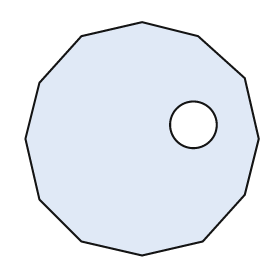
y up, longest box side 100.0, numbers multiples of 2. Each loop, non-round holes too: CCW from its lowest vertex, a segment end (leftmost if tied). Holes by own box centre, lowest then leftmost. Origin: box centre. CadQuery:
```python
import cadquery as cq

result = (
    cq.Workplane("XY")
    .moveTo(0.0, -50.0)
    .lineTo(26.0, -44.0)
    .lineTo(44.0, -24.0)
    .lineTo(50.0, 0.0)
    .lineTo(44.0, 26.0)
    .lineTo(24.0, 44.0)
    .lineTo(0.0, 50.0)
    .lineTo(-26.0, 44.0)
    .lineTo(-44.0, 24.0)
    .lineTo(-50.0, 0.0)
    .lineTo(-44.0, -26.0)
    .lineTo(-26.0, -44.0)
    .close()
    .moveTo(22.0, 6.0)
    .circle(10.0)
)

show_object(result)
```